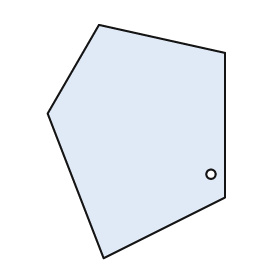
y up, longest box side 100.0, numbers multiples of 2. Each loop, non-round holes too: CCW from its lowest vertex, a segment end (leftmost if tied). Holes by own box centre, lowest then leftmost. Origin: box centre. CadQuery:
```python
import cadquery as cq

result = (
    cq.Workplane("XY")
    .moveTo(-14.0, -50.0)
    .lineTo(38.0, -24.0)
    .lineTo(38.0, 38.0)
    .lineTo(-16.0, 50.0)
    .lineTo(-38.0, 12.0)
    .close()
    .moveTo(32.0, -14.0)
    .circle(2.0)
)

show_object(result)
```